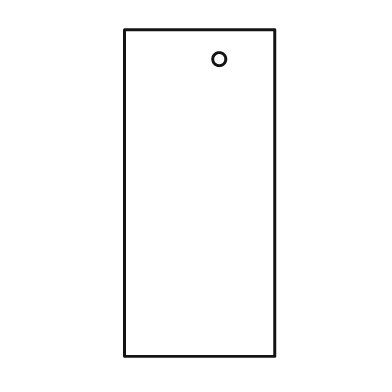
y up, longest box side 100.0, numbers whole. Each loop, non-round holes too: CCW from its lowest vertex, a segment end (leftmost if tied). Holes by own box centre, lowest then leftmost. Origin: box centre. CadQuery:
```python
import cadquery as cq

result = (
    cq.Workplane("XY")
    .moveTo(-23.0, -50.0)
    .lineTo(23.0, -50.0)
    .lineTo(23.0, 50.0)
    .lineTo(-23.0, 50.0)
    .close()
    .moveTo(6.0, 41.0)
    .circle(2.0)
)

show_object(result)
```